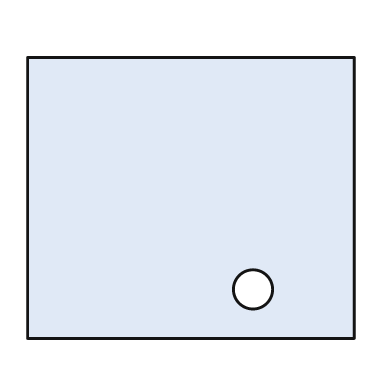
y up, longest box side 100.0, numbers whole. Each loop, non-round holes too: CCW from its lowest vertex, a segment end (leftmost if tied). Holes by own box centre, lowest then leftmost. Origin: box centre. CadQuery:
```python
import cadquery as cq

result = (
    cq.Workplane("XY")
    .moveTo(-50.0, -43.0)
    .lineTo(50.0, -43.0)
    .lineTo(50.0, 43.0)
    .lineTo(-50.0, 43.0)
    .close()
    .moveTo(19.0, -28.0)
    .circle(6.0)
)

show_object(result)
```